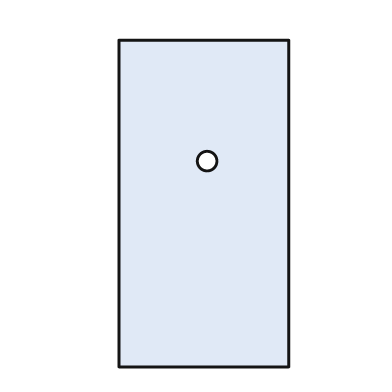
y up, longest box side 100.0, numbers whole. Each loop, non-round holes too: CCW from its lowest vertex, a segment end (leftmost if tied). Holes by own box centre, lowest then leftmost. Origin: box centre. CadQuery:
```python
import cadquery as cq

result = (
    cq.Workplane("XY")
    .moveTo(-26.0, -50.0)
    .lineTo(26.0, -50.0)
    .lineTo(26.0, 50.0)
    .lineTo(-26.0, 50.0)
    .close()
    .moveTo(1.0, 13.0)
    .circle(3.0)
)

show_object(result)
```